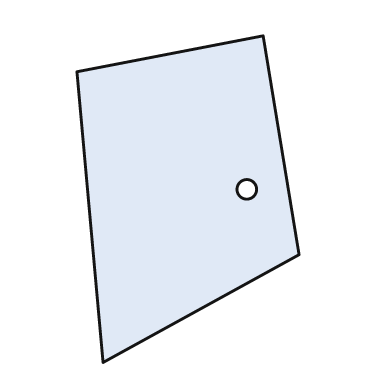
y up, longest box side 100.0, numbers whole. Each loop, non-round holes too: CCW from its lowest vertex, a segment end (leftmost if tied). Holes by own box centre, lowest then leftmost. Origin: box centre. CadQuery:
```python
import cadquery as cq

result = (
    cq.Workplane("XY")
    .moveTo(-26.0, -50.0)
    .lineTo(34.0, -17.0)
    .lineTo(23.0, 50.0)
    .lineTo(-34.0, 39.0)
    .close()
    .moveTo(18.0, 3.0)
    .circle(3.0)
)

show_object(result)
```